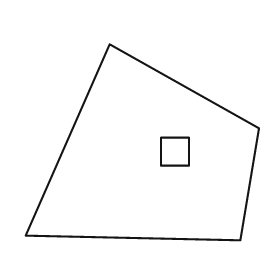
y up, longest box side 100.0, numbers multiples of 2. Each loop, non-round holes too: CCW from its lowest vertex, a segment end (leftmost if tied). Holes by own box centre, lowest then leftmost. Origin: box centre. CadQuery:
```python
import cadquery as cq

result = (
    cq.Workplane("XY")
    .moveTo(42.0, -42.0)
    .lineTo(50.0, 6.0)
    .lineTo(-14.0, 42.0)
    .lineTo(-50.0, -40.0)
    .close()
    .moveTo(8.0, -10.0)
    .lineTo(20.0, -10.0)
    .lineTo(20.0, 2.0)
    .lineTo(8.0, 2.0)
    .close()
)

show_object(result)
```